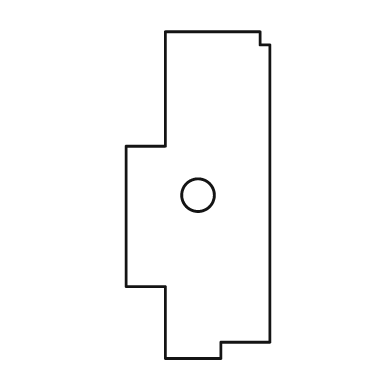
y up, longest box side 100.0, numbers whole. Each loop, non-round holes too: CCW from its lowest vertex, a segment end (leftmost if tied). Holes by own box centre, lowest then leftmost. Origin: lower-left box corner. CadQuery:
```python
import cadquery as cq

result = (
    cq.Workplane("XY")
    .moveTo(12.0, 0.0)
    .lineTo(29.0, 0.0)
    .lineTo(29.0, 5.0)
    .lineTo(44.0, 5.0)
    .lineTo(44.0, 96.0)
    .lineTo(41.0, 96.0)
    .lineTo(41.0, 100.0)
    .lineTo(12.0, 100.0)
    .lineTo(12.0, 65.0)
    .lineTo(0.0, 65.0)
    .lineTo(0.0, 22.0)
    .lineTo(12.0, 22.0)
    .close()
    .moveTo(22.0, 50.0)
    .circle(5.0)
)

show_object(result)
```